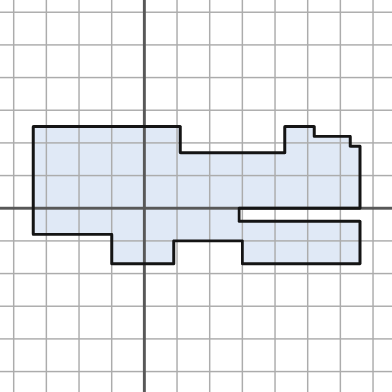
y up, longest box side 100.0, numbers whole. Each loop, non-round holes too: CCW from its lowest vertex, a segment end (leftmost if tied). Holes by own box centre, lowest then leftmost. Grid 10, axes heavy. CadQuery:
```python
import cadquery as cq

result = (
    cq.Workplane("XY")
    .moveTo(-10.0, -17.0)
    .lineTo(9.0, -17.0)
    .lineTo(9.0, -10.0)
    .lineTo(30.0, -10.0)
    .lineTo(30.0, -17.0)
    .lineTo(66.0, -17.0)
    .lineTo(66.0, -4.0)
    .lineTo(29.0, -4.0)
    .lineTo(29.0, 0.0)
    .lineTo(66.0, 0.0)
    .lineTo(66.0, 19.0)
    .lineTo(63.0, 19.0)
    .lineTo(63.0, 22.0)
    .lineTo(52.0, 22.0)
    .lineTo(52.0, 25.0)
    .lineTo(43.0, 25.0)
    .lineTo(43.0, 17.0)
    .lineTo(11.0, 17.0)
    .lineTo(11.0, 25.0)
    .lineTo(-34.0, 25.0)
    .lineTo(-34.0, -8.0)
    .lineTo(-10.0, -8.0)
    .close()
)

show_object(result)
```